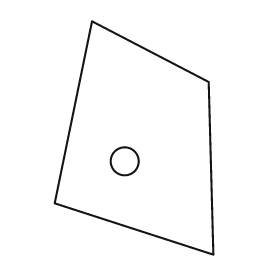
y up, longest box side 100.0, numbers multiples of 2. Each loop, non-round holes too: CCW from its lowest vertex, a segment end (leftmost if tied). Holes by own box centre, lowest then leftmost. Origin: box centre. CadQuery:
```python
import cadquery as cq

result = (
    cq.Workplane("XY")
    .moveTo(34.0, -50.0)
    .lineTo(32.0, 24.0)
    .lineTo(-18.0, 50.0)
    .lineTo(-34.0, -28.0)
    .close()
    .moveTo(-4.0, -10.0)
    .circle(6.0)
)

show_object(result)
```